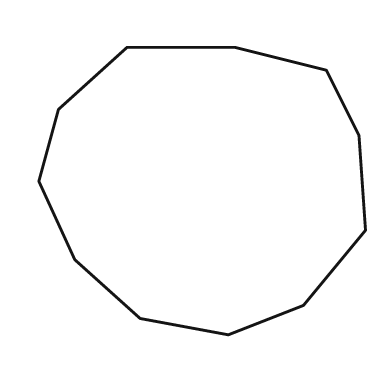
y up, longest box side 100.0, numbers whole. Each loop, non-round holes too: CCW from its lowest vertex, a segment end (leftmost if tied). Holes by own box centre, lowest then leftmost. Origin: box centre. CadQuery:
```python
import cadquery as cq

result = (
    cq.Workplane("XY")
    .moveTo(8.0, -44.0)
    .lineTo(31.0, -35.0)
    .lineTo(50.0, -12.0)
    .lineTo(48.0, 17.0)
    .lineTo(38.0, 37.0)
    .lineTo(10.0, 44.0)
    .lineTo(-23.0, 44.0)
    .lineTo(-44.0, 25.0)
    .lineTo(-50.0, 3.0)
    .lineTo(-39.0, -21.0)
    .lineTo(-19.0, -39.0)
    .close()
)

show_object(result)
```